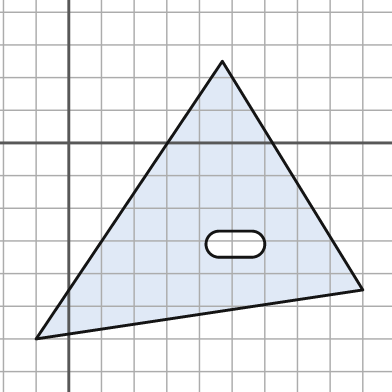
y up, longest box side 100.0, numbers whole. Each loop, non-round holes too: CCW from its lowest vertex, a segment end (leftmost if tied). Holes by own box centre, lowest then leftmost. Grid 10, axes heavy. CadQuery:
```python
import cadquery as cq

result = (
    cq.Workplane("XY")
    .moveTo(-10.0, -60.0)
    .lineTo(90.0, -45.0)
    .lineTo(47.0, 25.0)
    .close()
    .moveTo(46.0, -35.0)
    .lineTo(56.0, -35.0)
    .threePointArc((60.0, -31.0), (56.0, -27.0))
    .lineTo(46.0, -27.0)
    .threePointArc((42.0, -31.0), (46.0, -35.0))
    .close()
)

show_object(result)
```